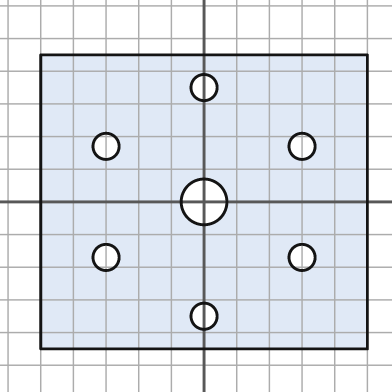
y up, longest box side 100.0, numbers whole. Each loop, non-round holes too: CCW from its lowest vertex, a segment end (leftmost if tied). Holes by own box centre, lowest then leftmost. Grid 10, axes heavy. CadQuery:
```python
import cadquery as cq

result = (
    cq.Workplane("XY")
    .moveTo(-50.0, -45.0)
    .lineTo(50.0, -45.0)
    .lineTo(50.0, 45.0)
    .lineTo(-50.0, 45.0)
    .close()
    .moveTo(0.0, -35.0)
    .circle(4.0)
    .moveTo(-30.0, -17.0)
    .circle(4.0)
    .moveTo(30.0, -17.0)
    .circle(4.0)
    .moveTo(0.0, 0.0)
    .circle(7.0)
    .moveTo(-30.0, 17.0)
    .circle(4.0)
    .moveTo(30.0, 17.0)
    .circle(4.0)
    .moveTo(0.0, 35.0)
    .circle(4.0)
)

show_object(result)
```